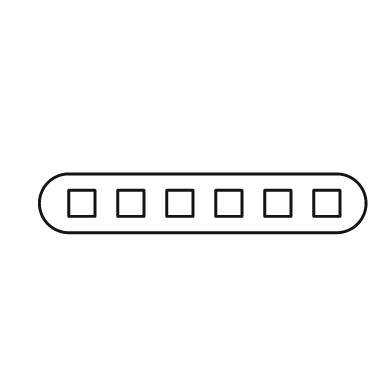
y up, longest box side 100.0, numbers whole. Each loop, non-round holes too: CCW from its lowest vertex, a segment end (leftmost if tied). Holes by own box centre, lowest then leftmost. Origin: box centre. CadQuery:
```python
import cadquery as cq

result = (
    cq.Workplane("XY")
    .moveTo(-41.0, -9.0)
    .lineTo(41.0, -9.0)
    .threePointArc((50.0, 0.0), (41.0, 9.0))
    .lineTo(-41.0, 9.0)
    .threePointArc((-50.0, 0.0), (-41.0, -9.0))
    .close()
    .moveTo(-41.0, -4.0)
    .lineTo(-33.0, -4.0)
    .lineTo(-33.0, 4.0)
    .lineTo(-41.0, 4.0)
    .close()
    .moveTo(-26.0, -4.0)
    .lineTo(-18.0, -4.0)
    .lineTo(-18.0, 4.0)
    .lineTo(-26.0, 4.0)
    .close()
    .moveTo(-11.0, -4.0)
    .lineTo(-3.0, -4.0)
    .lineTo(-3.0, 4.0)
    .lineTo(-11.0, 4.0)
    .close()
    .moveTo(4.0, -4.0)
    .lineTo(12.0, -4.0)
    .lineTo(12.0, 4.0)
    .lineTo(4.0, 4.0)
    .close()
    .moveTo(19.0, -4.0)
    .lineTo(27.0, -4.0)
    .lineTo(27.0, 4.0)
    .lineTo(19.0, 4.0)
    .close()
    .moveTo(34.0, -4.0)
    .lineTo(42.0, -4.0)
    .lineTo(42.0, 4.0)
    .lineTo(34.0, 4.0)
    .close()
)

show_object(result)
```